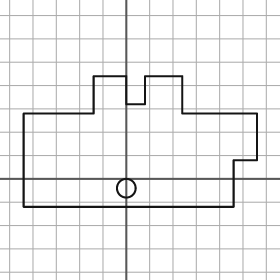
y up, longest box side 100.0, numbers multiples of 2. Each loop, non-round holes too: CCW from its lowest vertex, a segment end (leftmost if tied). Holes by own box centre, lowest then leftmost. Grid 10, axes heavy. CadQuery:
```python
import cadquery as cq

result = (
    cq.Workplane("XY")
    .moveTo(-44.0, -12.0)
    .lineTo(46.0, -12.0)
    .lineTo(46.0, 8.0)
    .lineTo(56.0, 8.0)
    .lineTo(56.0, 28.0)
    .lineTo(24.0, 28.0)
    .lineTo(24.0, 44.0)
    .lineTo(8.0, 44.0)
    .lineTo(8.0, 32.0)
    .lineTo(0.0, 32.0)
    .lineTo(0.0, 44.0)
    .lineTo(-14.0, 44.0)
    .lineTo(-14.0, 28.0)
    .lineTo(-44.0, 28.0)
    .close()
    .moveTo(0.0, -4.0)
    .circle(4.0)
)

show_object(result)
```